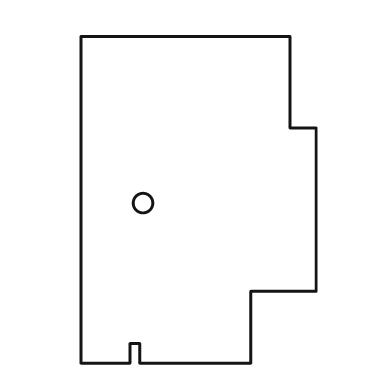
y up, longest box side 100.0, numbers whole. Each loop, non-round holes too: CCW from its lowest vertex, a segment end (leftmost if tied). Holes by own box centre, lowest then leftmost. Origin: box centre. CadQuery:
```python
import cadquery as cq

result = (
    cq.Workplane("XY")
    .moveTo(-36.0, -50.0)
    .lineTo(-21.0, -50.0)
    .lineTo(-21.0, -44.0)
    .lineTo(-18.0, -44.0)
    .lineTo(-18.0, -50.0)
    .lineTo(16.0, -50.0)
    .lineTo(16.0, -28.0)
    .lineTo(36.0, -28.0)
    .lineTo(36.0, 22.0)
    .lineTo(28.0, 22.0)
    .lineTo(28.0, 50.0)
    .lineTo(-36.0, 50.0)
    .close()
    .moveTo(-17.0, -1.0)
    .circle(3.0)
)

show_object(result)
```